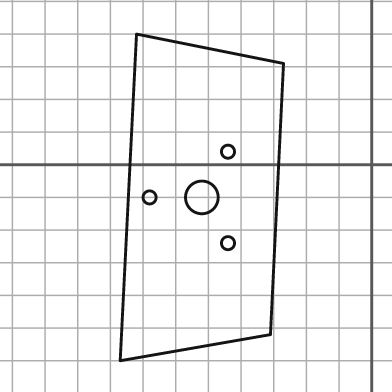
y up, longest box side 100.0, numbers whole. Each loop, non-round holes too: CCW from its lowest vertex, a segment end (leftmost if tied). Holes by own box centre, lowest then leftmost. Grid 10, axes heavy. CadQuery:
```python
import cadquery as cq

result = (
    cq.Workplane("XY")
    .moveTo(-77.0, -60.0)
    .lineTo(-31.0, -52.0)
    .lineTo(-27.0, 31.0)
    .lineTo(-72.0, 40.0)
    .close()
    .moveTo(-44.0, -24.0)
    .circle(2.0)
    .moveTo(-68.0, -10.0)
    .circle(2.0)
    .moveTo(-52.0, -10.0)
    .circle(5.0)
    .moveTo(-44.0, 4.0)
    .circle(2.0)
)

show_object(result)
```